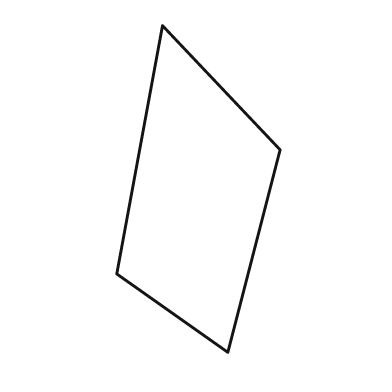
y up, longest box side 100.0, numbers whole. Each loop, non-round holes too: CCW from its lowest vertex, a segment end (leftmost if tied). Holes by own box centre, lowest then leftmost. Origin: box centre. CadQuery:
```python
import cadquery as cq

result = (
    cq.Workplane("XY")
    .moveTo(9.0, -50.0)
    .lineTo(25.0, 12.0)
    .lineTo(-11.0, 50.0)
    .lineTo(-25.0, -26.0)
    .close()
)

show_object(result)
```